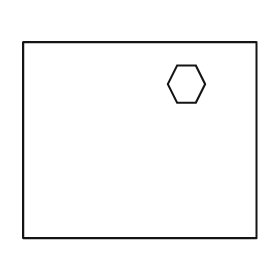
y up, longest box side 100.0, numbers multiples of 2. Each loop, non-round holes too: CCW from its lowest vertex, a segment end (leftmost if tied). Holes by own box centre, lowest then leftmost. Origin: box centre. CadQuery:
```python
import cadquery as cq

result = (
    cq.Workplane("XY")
    .moveTo(-50.0, -42.0)
    .lineTo(50.0, -42.0)
    .lineTo(50.0, 42.0)
    .lineTo(-50.0, 42.0)
    .close()
    .moveTo(16.0, 16.0)
    .lineTo(24.0, 16.0)
    .lineTo(28.0, 24.0)
    .lineTo(24.0, 32.0)
    .lineTo(16.0, 32.0)
    .lineTo(12.0, 24.0)
    .close()
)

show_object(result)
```